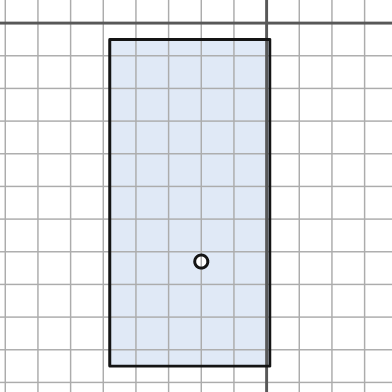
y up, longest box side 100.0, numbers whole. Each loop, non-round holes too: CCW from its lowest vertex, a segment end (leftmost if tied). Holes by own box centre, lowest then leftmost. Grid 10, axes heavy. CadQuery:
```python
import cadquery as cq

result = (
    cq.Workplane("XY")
    .moveTo(-48.0, -105.0)
    .lineTo(1.0, -105.0)
    .lineTo(1.0, -5.0)
    .lineTo(-48.0, -5.0)
    .close()
    .moveTo(-20.0, -73.0)
    .circle(2.0)
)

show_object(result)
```